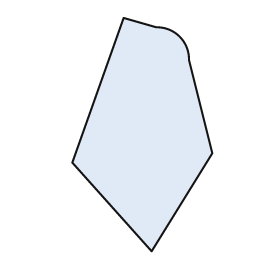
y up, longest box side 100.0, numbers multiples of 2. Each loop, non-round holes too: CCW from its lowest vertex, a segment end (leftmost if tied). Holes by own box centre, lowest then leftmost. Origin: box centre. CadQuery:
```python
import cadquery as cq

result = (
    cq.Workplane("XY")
    .moveTo(4.0, -50.0)
    .lineTo(30.0, -8.0)
    .lineTo(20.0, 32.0)
    .threePointArc((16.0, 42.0), (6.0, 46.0))
    .lineTo(-8.0, 50.0)
    .lineTo(-30.0, -12.0)
    .close()
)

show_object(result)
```